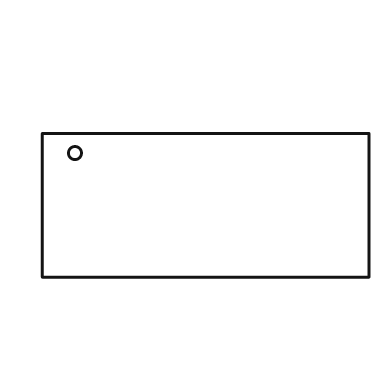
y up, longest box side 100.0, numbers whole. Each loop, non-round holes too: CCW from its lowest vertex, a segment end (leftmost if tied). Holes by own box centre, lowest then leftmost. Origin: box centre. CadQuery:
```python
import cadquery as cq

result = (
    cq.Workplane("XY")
    .moveTo(-50.0, -22.0)
    .lineTo(50.0, -22.0)
    .lineTo(50.0, 22.0)
    .lineTo(-50.0, 22.0)
    .close()
    .moveTo(-40.0, 16.0)
    .circle(2.0)
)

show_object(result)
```